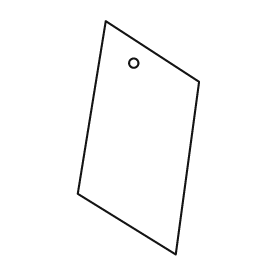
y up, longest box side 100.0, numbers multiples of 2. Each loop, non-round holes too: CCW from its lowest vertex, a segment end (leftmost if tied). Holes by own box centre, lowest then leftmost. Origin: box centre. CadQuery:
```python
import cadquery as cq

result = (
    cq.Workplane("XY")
    .moveTo(16.0, -50.0)
    .lineTo(26.0, 24.0)
    .lineTo(-14.0, 50.0)
    .lineTo(-26.0, -24.0)
    .close()
    .moveTo(-2.0, 32.0)
    .circle(2.0)
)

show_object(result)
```